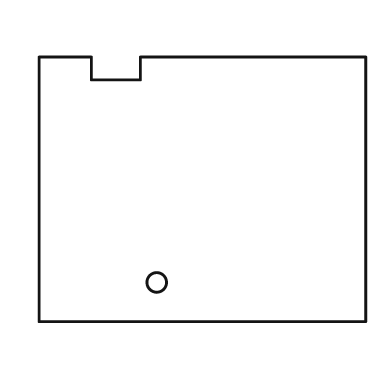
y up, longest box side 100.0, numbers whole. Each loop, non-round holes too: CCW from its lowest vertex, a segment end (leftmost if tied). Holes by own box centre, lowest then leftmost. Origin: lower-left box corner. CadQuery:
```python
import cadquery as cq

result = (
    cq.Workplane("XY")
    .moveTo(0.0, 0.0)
    .lineTo(100.0, 0.0)
    .lineTo(100.0, 81.0)
    .lineTo(31.0, 81.0)
    .lineTo(31.0, 74.0)
    .lineTo(16.0, 74.0)
    .lineTo(16.0, 81.0)
    .lineTo(0.0, 81.0)
    .close()
    .moveTo(36.0, 12.0)
    .circle(3.0)
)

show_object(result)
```